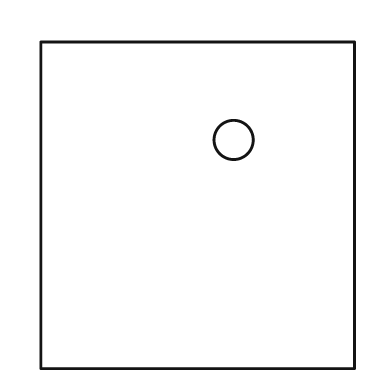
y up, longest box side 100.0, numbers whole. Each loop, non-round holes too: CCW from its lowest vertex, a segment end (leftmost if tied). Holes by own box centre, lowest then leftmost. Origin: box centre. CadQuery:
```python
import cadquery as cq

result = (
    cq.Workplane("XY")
    .moveTo(-48.0, -50.0)
    .lineTo(48.0, -50.0)
    .lineTo(48.0, 50.0)
    .lineTo(-48.0, 50.0)
    .close()
    .moveTo(11.0, 20.0)
    .circle(6.0)
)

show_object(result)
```